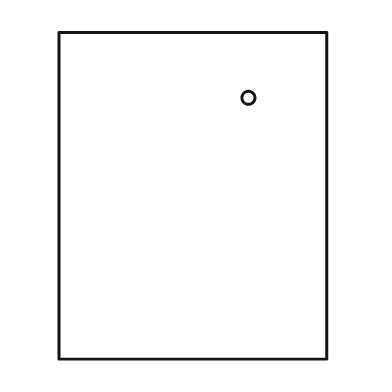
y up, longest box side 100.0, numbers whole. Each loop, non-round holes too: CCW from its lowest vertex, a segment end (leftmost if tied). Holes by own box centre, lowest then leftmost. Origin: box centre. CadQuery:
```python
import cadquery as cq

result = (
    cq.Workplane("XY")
    .moveTo(-41.0, -50.0)
    .lineTo(41.0, -50.0)
    .lineTo(41.0, 50.0)
    .lineTo(-41.0, 50.0)
    .close()
    .moveTo(17.0, 30.0)
    .circle(2.0)
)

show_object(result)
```